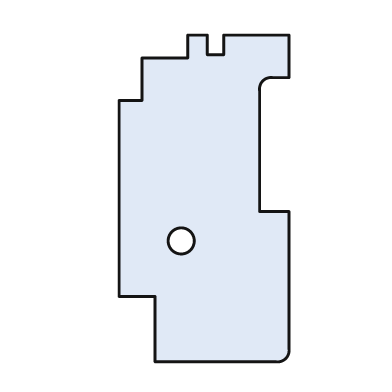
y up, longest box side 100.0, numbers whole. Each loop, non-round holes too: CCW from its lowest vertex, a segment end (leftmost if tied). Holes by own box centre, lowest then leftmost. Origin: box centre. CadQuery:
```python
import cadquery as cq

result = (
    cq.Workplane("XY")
    .moveTo(-15.0, -50.0)
    .lineTo(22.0, -50.0)
    .threePointArc((25.0, -49.0), (26.0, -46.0))
    .lineTo(26.0, -4.0)
    .lineTo(17.0, -4.0)
    .lineTo(17.0, 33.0)
    .threePointArc((18.0, 36.0), (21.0, 37.0))
    .lineTo(26.0, 37.0)
    .lineTo(26.0, 50.0)
    .lineTo(6.0, 50.0)
    .lineTo(6.0, 44.0)
    .lineTo(1.0, 44.0)
    .lineTo(1.0, 50.0)
    .lineTo(-5.0, 50.0)
    .lineTo(-5.0, 43.0)
    .lineTo(-19.0, 43.0)
    .lineTo(-19.0, 30.0)
    .lineTo(-26.0, 30.0)
    .lineTo(-26.0, -30.0)
    .lineTo(-15.0, -30.0)
    .close()
    .moveTo(-7.0, -13.0)
    .circle(4.0)
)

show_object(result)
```